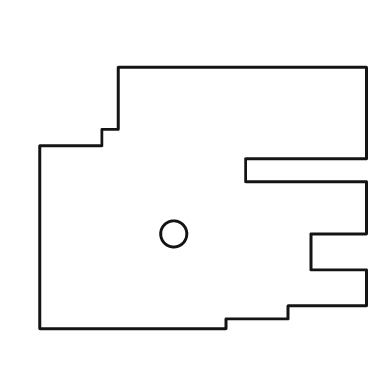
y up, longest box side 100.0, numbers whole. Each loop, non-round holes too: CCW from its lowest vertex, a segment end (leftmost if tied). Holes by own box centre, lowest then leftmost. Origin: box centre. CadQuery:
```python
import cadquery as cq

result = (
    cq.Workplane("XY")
    .moveTo(-50.0, -40.0)
    .lineTo(7.0, -40.0)
    .lineTo(7.0, -37.0)
    .lineTo(26.0, -37.0)
    .lineTo(26.0, -33.0)
    .lineTo(50.0, -33.0)
    .lineTo(50.0, -22.0)
    .lineTo(33.0, -22.0)
    .lineTo(33.0, -11.0)
    .lineTo(50.0, -11.0)
    .lineTo(50.0, 5.0)
    .lineTo(13.0, 5.0)
    .lineTo(13.0, 12.0)
    .lineTo(50.0, 12.0)
    .lineTo(50.0, 40.0)
    .lineTo(-26.0, 40.0)
    .lineTo(-26.0, 21.0)
    .lineTo(-31.0, 21.0)
    .lineTo(-31.0, 16.0)
    .lineTo(-50.0, 16.0)
    .close()
    .moveTo(-9.0, -11.0)
    .circle(4.0)
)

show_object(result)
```